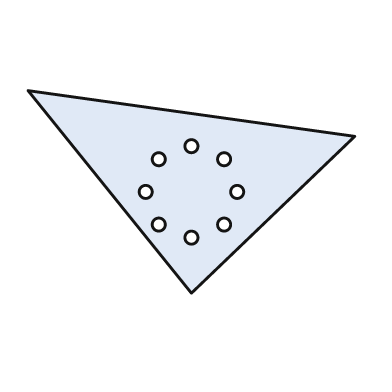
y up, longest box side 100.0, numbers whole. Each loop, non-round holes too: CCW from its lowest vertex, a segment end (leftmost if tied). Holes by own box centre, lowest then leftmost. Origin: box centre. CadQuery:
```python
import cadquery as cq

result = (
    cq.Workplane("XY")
    .moveTo(0.0, -31.0)
    .lineTo(50.0, 17.0)
    .lineTo(-50.0, 31.0)
    .close()
    .moveTo(0.0, -14.0)
    .circle(2.0)
    .moveTo(-10.0, -10.0)
    .circle(2.0)
    .moveTo(10.0, -10.0)
    .circle(2.0)
    .moveTo(-14.0, 0.0)
    .circle(2.0)
    .moveTo(14.0, 0.0)
    .circle(2.0)
    .moveTo(-10.0, 10.0)
    .circle(2.0)
    .moveTo(10.0, 10.0)
    .circle(2.0)
    .moveTo(0.0, 14.0)
    .circle(2.0)
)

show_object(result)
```